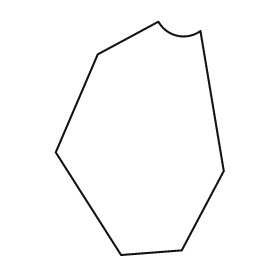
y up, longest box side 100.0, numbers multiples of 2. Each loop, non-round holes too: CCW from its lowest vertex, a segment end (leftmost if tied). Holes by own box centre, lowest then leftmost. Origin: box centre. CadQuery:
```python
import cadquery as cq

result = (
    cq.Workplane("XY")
    .moveTo(-8.0, -50.0)
    .lineTo(18.0, -48.0)
    .lineTo(36.0, -14.0)
    .lineTo(26.0, 46.0)
    .threePointArc((16.0, 44.0), (8.0, 50.0))
    .lineTo(-18.0, 36.0)
    .lineTo(-36.0, -6.0)
    .close()
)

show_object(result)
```